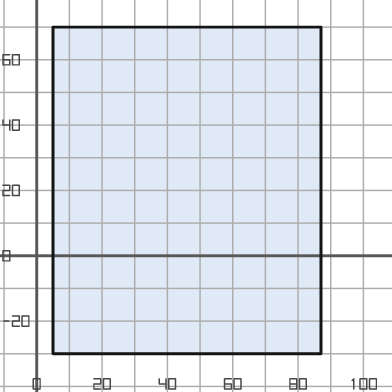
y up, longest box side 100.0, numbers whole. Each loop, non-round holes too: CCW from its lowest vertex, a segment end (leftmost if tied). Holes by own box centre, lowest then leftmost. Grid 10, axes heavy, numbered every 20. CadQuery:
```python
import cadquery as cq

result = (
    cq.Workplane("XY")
    .moveTo(5.0, -30.0)
    .lineTo(87.0, -30.0)
    .lineTo(87.0, 70.0)
    .lineTo(5.0, 70.0)
    .close()
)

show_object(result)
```